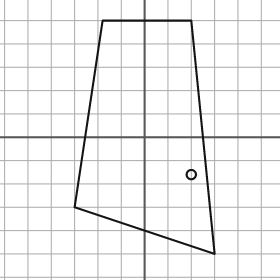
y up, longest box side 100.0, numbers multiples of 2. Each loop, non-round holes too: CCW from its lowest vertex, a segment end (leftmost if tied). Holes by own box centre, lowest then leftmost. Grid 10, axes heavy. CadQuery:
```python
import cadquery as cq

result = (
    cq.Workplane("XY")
    .moveTo(30.0, -50.0)
    .lineTo(20.0, 50.0)
    .lineTo(-18.0, 50.0)
    .lineTo(-30.0, -30.0)
    .close()
    .moveTo(20.0, -16.0)
    .circle(2.0)
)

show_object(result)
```